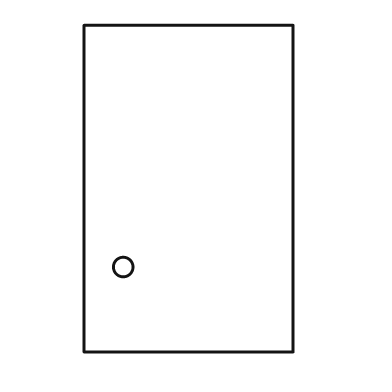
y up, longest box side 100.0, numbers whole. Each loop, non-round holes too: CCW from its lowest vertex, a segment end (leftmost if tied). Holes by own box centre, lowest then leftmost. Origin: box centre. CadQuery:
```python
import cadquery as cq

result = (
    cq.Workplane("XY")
    .moveTo(-32.0, -50.0)
    .lineTo(32.0, -50.0)
    .lineTo(32.0, 50.0)
    .lineTo(-32.0, 50.0)
    .close()
    .moveTo(-20.0, -24.0)
    .circle(3.0)
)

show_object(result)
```